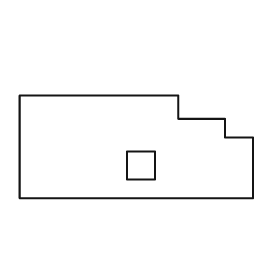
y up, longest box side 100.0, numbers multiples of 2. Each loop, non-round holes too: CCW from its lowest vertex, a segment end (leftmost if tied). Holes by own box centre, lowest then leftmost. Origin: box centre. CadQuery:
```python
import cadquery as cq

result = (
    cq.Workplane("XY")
    .moveTo(-50.0, -22.0)
    .lineTo(50.0, -22.0)
    .lineTo(50.0, 4.0)
    .lineTo(38.0, 4.0)
    .lineTo(38.0, 12.0)
    .lineTo(18.0, 12.0)
    .lineTo(18.0, 22.0)
    .lineTo(-50.0, 22.0)
    .close()
    .moveTo(-4.0, -14.0)
    .lineTo(8.0, -14.0)
    .lineTo(8.0, -2.0)
    .lineTo(-4.0, -2.0)
    .close()
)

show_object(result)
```